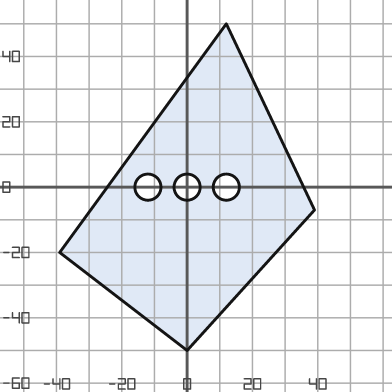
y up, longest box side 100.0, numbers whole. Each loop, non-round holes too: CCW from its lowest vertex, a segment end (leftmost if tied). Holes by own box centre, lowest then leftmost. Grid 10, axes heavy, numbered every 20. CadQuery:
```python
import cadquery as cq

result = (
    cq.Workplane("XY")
    .moveTo(0.0, -50.0)
    .lineTo(39.0, -7.0)
    .lineTo(12.0, 50.0)
    .lineTo(-39.0, -20.0)
    .close()
    .moveTo(-12.0, 0.0)
    .circle(4.0)
    .moveTo(0.0, 0.0)
    .circle(4.0)
    .moveTo(12.0, 0.0)
    .circle(4.0)
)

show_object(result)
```